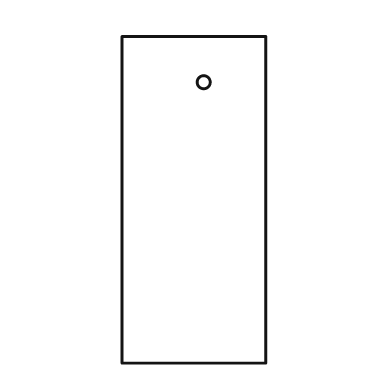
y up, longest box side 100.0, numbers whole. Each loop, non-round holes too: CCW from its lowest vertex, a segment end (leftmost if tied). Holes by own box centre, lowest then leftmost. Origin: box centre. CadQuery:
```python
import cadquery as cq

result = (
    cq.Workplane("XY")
    .moveTo(-22.0, -50.0)
    .lineTo(22.0, -50.0)
    .lineTo(22.0, 50.0)
    .lineTo(-22.0, 50.0)
    .close()
    .moveTo(3.0, 36.0)
    .circle(2.0)
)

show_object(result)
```